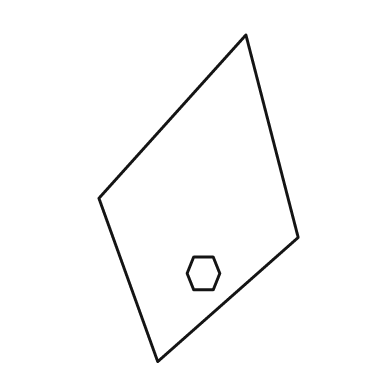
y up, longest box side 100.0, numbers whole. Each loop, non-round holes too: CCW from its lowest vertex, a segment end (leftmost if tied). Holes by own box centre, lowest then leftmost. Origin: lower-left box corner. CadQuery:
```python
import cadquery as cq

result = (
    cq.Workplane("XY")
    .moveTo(18.0, 0.0)
    .lineTo(61.0, 38.0)
    .lineTo(45.0, 100.0)
    .lineTo(0.0, 50.0)
    .close()
    .moveTo(29.0, 22.0)
    .lineTo(35.0, 22.0)
    .lineTo(37.0, 27.0)
    .lineTo(35.0, 32.0)
    .lineTo(29.0, 32.0)
    .lineTo(27.0, 27.0)
    .close()
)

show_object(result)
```